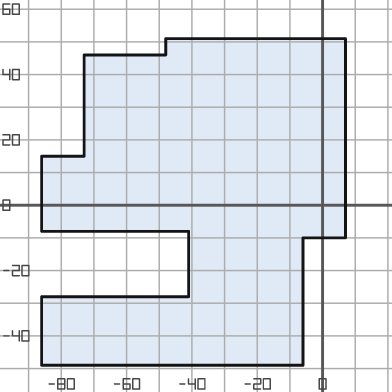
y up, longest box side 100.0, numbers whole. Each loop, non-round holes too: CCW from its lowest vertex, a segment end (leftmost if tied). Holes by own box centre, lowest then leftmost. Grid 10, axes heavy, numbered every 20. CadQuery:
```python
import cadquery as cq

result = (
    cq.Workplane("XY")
    .moveTo(-86.0, -49.0)
    .lineTo(-6.0, -49.0)
    .lineTo(-6.0, -10.0)
    .lineTo(7.0, -10.0)
    .lineTo(7.0, 51.0)
    .lineTo(-48.0, 51.0)
    .lineTo(-48.0, 46.0)
    .lineTo(-73.0, 46.0)
    .lineTo(-73.0, 15.0)
    .lineTo(-86.0, 15.0)
    .lineTo(-86.0, -8.0)
    .lineTo(-41.0, -8.0)
    .lineTo(-41.0, -28.0)
    .lineTo(-86.0, -28.0)
    .close()
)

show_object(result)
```